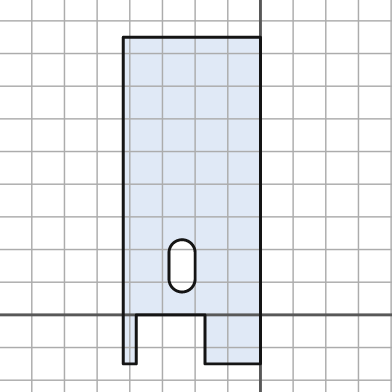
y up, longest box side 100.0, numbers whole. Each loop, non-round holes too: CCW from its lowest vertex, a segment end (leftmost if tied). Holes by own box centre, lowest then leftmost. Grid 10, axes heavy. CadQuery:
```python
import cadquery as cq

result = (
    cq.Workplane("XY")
    .moveTo(-42.0, -15.0)
    .lineTo(-38.0, -15.0)
    .lineTo(-38.0, 0.0)
    .lineTo(-17.0, 0.0)
    .lineTo(-17.0, -15.0)
    .lineTo(0.0, -15.0)
    .lineTo(0.0, 85.0)
    .lineTo(-42.0, 85.0)
    .close()
    .moveTo(-28.0, 11.0)
    .threePointArc((-24.0, 7.0), (-20.0, 11.0))
    .lineTo(-20.0, 19.0)
    .threePointArc((-24.0, 23.0), (-28.0, 19.0))
    .close()
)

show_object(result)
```